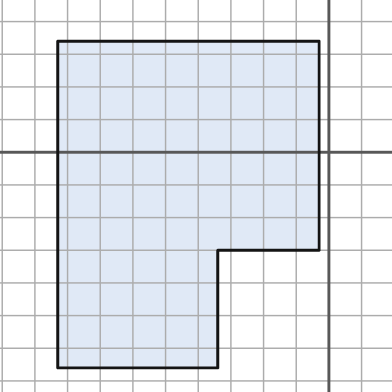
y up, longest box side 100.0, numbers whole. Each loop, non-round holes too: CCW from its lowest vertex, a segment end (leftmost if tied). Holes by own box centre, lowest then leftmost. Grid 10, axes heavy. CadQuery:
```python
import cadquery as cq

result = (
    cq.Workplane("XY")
    .moveTo(-83.0, -66.0)
    .lineTo(-34.0, -66.0)
    .lineTo(-34.0, -30.0)
    .lineTo(-3.0, -30.0)
    .lineTo(-3.0, 34.0)
    .lineTo(-83.0, 34.0)
    .close()
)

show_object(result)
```